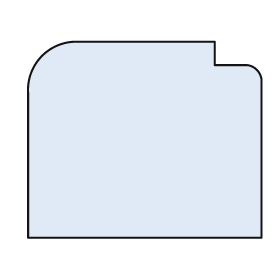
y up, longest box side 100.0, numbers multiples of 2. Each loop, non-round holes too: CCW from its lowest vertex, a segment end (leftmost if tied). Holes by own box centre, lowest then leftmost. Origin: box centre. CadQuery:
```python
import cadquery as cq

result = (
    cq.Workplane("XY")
    .moveTo(-50.0, -42.0)
    .lineTo(50.0, -42.0)
    .lineTo(50.0, 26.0)
    .threePointArc((48.0, 30.0), (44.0, 32.0))
    .lineTo(30.0, 32.0)
    .lineTo(30.0, 42.0)
    .lineTo(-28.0, 42.0)
    .threePointArc((-44.0, 36.0), (-50.0, 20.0))
    .close()
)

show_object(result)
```